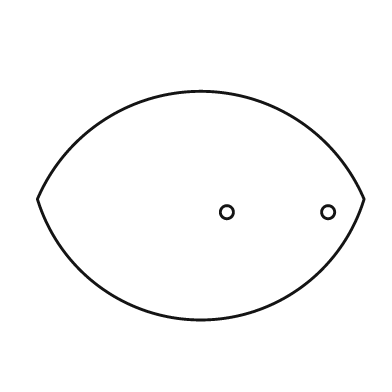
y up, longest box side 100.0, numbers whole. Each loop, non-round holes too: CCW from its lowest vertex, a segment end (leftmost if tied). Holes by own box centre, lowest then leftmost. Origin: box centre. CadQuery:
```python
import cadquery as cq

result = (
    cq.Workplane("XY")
    .moveTo(-50.0, 2.0)
    .threePointArc((0.0, -35.0), (50.0, 2.0))
    .threePointArc((0.0, 35.0), (-50.0, 2.0))
    .close()
    .moveTo(8.0, -2.0)
    .circle(2.0)
    .moveTo(39.0, -2.0)
    .circle(2.0)
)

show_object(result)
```